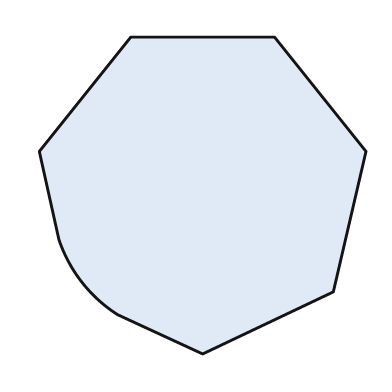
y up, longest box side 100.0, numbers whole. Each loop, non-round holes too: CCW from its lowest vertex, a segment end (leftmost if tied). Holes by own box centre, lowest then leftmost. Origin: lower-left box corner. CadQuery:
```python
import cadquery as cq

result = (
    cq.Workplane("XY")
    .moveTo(50.0, 0.0)
    .lineTo(90.0, 19.0)
    .lineTo(100.0, 62.0)
    .lineTo(72.0, 97.0)
    .lineTo(28.0, 97.0)
    .lineTo(0.0, 62.0)
    .lineTo(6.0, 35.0)
    .threePointArc((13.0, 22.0), (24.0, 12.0))
    .close()
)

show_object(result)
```